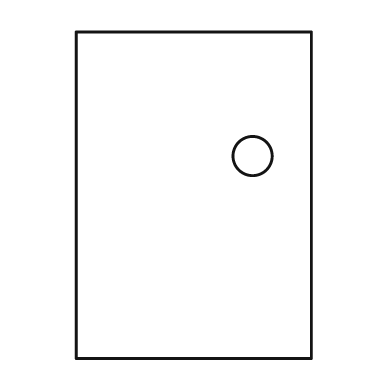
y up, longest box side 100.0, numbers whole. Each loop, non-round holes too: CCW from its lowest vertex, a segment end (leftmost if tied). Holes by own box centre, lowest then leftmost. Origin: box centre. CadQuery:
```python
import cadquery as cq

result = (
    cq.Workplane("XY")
    .moveTo(-36.0, -50.0)
    .lineTo(36.0, -50.0)
    .lineTo(36.0, 50.0)
    .lineTo(-36.0, 50.0)
    .close()
    .moveTo(18.0, 12.0)
    .circle(6.0)
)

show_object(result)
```